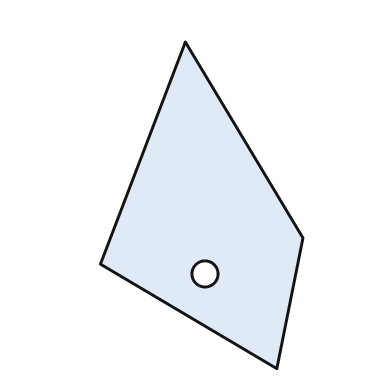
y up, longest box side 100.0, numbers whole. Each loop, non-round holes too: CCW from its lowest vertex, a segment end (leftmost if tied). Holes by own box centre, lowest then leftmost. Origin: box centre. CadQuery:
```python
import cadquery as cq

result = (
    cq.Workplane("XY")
    .moveTo(23.0, -50.0)
    .lineTo(31.0, -10.0)
    .lineTo(-5.0, 50.0)
    .lineTo(-31.0, -18.0)
    .close()
    .moveTo(1.0, -21.0)
    .circle(4.0)
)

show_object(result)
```